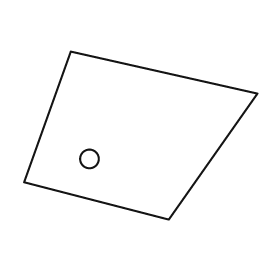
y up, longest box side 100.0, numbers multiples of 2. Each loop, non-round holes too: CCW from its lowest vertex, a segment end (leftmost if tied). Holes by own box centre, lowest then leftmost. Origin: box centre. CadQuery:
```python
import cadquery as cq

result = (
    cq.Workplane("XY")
    .moveTo(12.0, -36.0)
    .lineTo(50.0, 18.0)
    .lineTo(-30.0, 36.0)
    .lineTo(-50.0, -20.0)
    .close()
    .moveTo(-22.0, -10.0)
    .circle(4.0)
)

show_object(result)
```